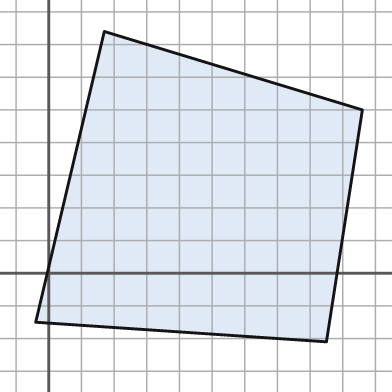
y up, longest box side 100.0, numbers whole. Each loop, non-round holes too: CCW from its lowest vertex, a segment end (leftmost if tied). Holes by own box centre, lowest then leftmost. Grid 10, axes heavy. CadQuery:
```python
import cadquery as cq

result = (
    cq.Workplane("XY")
    .moveTo(85.0, -21.0)
    .lineTo(96.0, 50.0)
    .lineTo(17.0, 74.0)
    .lineTo(-4.0, -15.0)
    .close()
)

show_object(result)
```